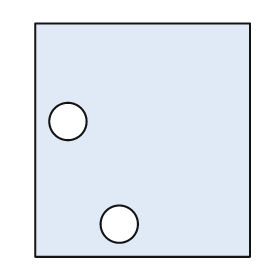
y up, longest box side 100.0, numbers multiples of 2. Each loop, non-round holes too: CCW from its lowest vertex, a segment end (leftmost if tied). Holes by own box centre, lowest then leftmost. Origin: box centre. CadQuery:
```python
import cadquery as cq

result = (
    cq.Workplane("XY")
    .moveTo(-46.0, -50.0)
    .lineTo(46.0, -50.0)
    .lineTo(46.0, 50.0)
    .lineTo(-46.0, 50.0)
    .close()
    .moveTo(-10.0, -36.0)
    .circle(8.0)
    .moveTo(-32.0, 8.0)
    .circle(8.0)
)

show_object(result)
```